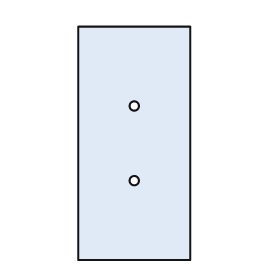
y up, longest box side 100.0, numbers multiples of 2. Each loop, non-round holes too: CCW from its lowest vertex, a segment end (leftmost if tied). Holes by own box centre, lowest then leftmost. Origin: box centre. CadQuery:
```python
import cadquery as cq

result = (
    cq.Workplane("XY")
    .moveTo(-24.0, -50.0)
    .lineTo(24.0, -50.0)
    .lineTo(24.0, 50.0)
    .lineTo(-24.0, 50.0)
    .close()
    .moveTo(0.0, -16.0)
    .circle(2.0)
    .moveTo(0.0, 16.0)
    .circle(2.0)
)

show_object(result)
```